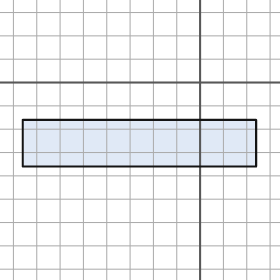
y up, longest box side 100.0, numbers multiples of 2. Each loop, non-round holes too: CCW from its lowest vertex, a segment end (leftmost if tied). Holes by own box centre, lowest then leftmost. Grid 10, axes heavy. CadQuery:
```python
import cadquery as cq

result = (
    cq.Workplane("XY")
    .moveTo(-76.0, -36.0)
    .lineTo(24.0, -36.0)
    .lineTo(24.0, -16.0)
    .lineTo(-76.0, -16.0)
    .close()
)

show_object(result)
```